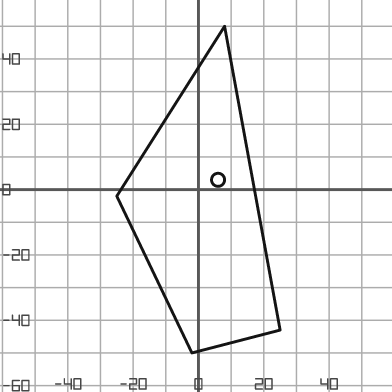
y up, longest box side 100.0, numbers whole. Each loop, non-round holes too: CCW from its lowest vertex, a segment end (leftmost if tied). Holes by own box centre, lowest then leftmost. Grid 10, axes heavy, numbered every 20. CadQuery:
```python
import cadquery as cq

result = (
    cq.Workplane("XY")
    .moveTo(-2.0, -50.0)
    .lineTo(25.0, -43.0)
    .lineTo(8.0, 50.0)
    .lineTo(-25.0, -2.0)
    .close()
    .moveTo(6.0, 3.0)
    .circle(2.0)
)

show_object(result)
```